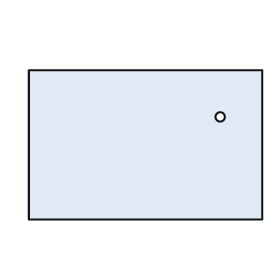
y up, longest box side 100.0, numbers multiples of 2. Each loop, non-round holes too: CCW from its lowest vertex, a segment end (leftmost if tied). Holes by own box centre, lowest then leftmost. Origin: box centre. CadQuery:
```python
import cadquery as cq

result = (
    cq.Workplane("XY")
    .moveTo(-50.0, -32.0)
    .lineTo(50.0, -32.0)
    .lineTo(50.0, 32.0)
    .lineTo(-50.0, 32.0)
    .close()
    .moveTo(32.0, 12.0)
    .circle(2.0)
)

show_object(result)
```